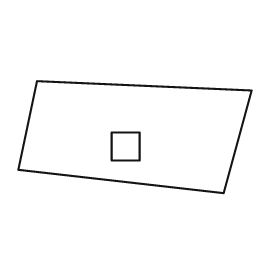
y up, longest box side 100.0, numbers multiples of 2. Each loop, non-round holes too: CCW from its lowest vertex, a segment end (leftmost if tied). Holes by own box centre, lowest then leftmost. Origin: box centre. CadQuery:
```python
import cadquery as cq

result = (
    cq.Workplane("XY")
    .moveTo(38.0, -24.0)
    .lineTo(50.0, 20.0)
    .lineTo(-42.0, 24.0)
    .lineTo(-50.0, -14.0)
    .close()
    .moveTo(-10.0, -10.0)
    .lineTo(2.0, -10.0)
    .lineTo(2.0, 2.0)
    .lineTo(-10.0, 2.0)
    .close()
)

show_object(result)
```